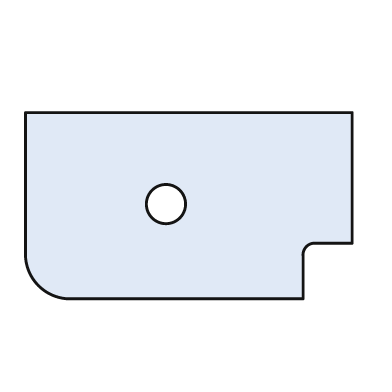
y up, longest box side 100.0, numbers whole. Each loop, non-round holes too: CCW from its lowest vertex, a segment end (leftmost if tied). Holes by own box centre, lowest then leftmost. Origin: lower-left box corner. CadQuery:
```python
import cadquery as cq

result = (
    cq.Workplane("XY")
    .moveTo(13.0, 0.0)
    .lineTo(85.0, 0.0)
    .lineTo(85.0, 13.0)
    .threePointArc((86.0, 16.0), (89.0, 17.0))
    .lineTo(100.0, 17.0)
    .lineTo(100.0, 57.0)
    .lineTo(0.0, 57.0)
    .lineTo(0.0, 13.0)
    .threePointArc((4.0, 4.0), (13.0, 0.0))
    .close()
    .moveTo(43.0, 29.0)
    .circle(6.0)
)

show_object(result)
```